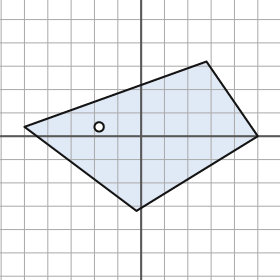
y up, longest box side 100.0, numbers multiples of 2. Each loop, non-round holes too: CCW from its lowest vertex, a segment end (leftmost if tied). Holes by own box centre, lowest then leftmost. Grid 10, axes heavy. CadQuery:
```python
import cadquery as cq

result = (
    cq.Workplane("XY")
    .moveTo(-2.0, -32.0)
    .lineTo(50.0, 0.0)
    .lineTo(28.0, 32.0)
    .lineTo(-50.0, 4.0)
    .close()
    .moveTo(-18.0, 4.0)
    .circle(2.0)
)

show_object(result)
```